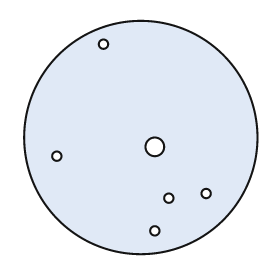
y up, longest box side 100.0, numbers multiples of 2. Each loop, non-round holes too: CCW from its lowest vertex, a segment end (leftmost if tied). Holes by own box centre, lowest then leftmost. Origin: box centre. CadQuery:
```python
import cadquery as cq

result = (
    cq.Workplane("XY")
    .moveTo(0.0, 0.0)
    .circle(50.0)
    .moveTo(6.0, -40.0)
    .circle(2.0)
    .moveTo(12.0, -26.0)
    .circle(2.0)
    .moveTo(28.0, -24.0)
    .circle(2.0)
    .moveTo(-36.0, -8.0)
    .circle(2.0)
    .moveTo(6.0, -4.0)
    .circle(4.0)
    .moveTo(-16.0, 40.0)
    .circle(2.0)
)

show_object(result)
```